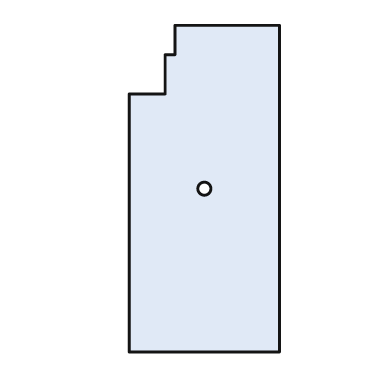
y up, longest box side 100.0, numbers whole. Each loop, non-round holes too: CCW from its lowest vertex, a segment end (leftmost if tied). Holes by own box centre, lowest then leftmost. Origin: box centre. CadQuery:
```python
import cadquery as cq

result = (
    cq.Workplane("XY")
    .moveTo(-23.0, -50.0)
    .lineTo(23.0, -50.0)
    .lineTo(23.0, 50.0)
    .lineTo(-9.0, 50.0)
    .lineTo(-9.0, 41.0)
    .lineTo(-12.0, 41.0)
    .lineTo(-12.0, 29.0)
    .lineTo(-23.0, 29.0)
    .close()
    .moveTo(0.0, 0.0)
    .circle(2.0)
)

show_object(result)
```